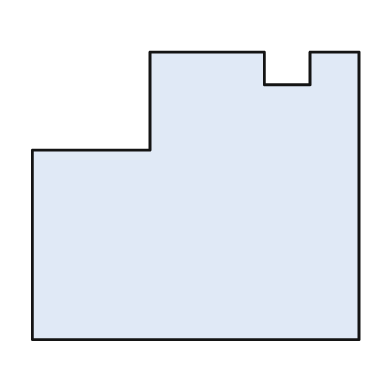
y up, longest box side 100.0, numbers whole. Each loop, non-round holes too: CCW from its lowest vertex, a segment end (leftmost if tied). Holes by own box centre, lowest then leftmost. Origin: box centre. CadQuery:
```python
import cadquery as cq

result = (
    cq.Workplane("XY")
    .moveTo(-50.0, -44.0)
    .lineTo(50.0, -44.0)
    .lineTo(50.0, 44.0)
    .lineTo(35.0, 44.0)
    .lineTo(35.0, 34.0)
    .lineTo(21.0, 34.0)
    .lineTo(21.0, 44.0)
    .lineTo(-14.0, 44.0)
    .lineTo(-14.0, 14.0)
    .lineTo(-50.0, 14.0)
    .close()
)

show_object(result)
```